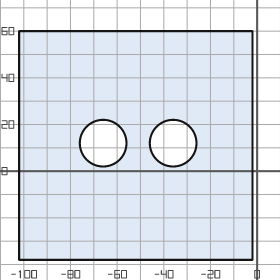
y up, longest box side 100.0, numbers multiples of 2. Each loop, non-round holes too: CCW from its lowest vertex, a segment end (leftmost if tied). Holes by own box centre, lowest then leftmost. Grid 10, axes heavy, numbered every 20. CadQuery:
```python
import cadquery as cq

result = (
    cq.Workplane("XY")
    .moveTo(-102.0, -38.0)
    .lineTo(-2.0, -38.0)
    .lineTo(-2.0, 60.0)
    .lineTo(-102.0, 60.0)
    .close()
    .moveTo(-66.0, 12.0)
    .circle(10.0)
    .moveTo(-36.0, 12.0)
    .circle(10.0)
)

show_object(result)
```